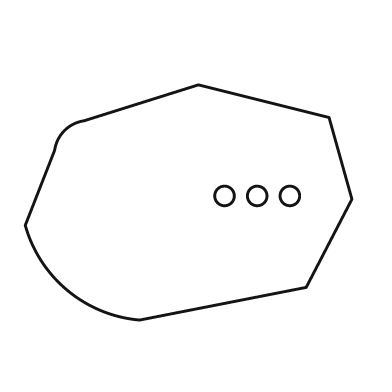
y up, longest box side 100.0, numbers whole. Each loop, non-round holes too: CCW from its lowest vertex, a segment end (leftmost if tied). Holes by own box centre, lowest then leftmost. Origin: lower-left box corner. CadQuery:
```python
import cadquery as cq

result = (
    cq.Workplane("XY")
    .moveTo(35.0, 0.0)
    .lineTo(86.0, 10.0)
    .lineTo(100.0, 37.0)
    .lineTo(93.0, 62.0)
    .lineTo(53.0, 72.0)
    .lineTo(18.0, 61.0)
    .threePointArc((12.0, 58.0), (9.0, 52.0))
    .lineTo(0.0, 29.0)
    .threePointArc((13.0, 9.0), (35.0, 0.0))
    .close()
    .moveTo(61.0, 38.0)
    .circle(3.0)
    .moveTo(71.0, 38.0)
    .circle(3.0)
    .moveTo(81.0, 38.0)
    .circle(3.0)
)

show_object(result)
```